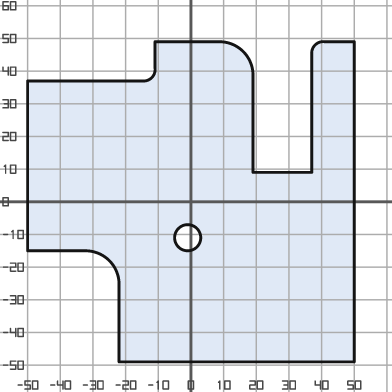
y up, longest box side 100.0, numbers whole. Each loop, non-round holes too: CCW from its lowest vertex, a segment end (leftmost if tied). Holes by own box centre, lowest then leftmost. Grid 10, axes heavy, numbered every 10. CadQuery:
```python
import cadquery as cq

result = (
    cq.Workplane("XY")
    .moveTo(-22.0, -49.0)
    .lineTo(50.0, -49.0)
    .lineTo(50.0, 49.0)
    .lineTo(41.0, 49.0)
    .threePointArc((38.0, 48.0), (37.0, 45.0))
    .lineTo(37.0, 9.0)
    .lineTo(19.0, 9.0)
    .lineTo(19.0, 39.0)
    .threePointArc((16.0, 46.0), (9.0, 49.0))
    .lineTo(-11.0, 49.0)
    .lineTo(-11.0, 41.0)
    .threePointArc((-12.0, 38.0), (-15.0, 37.0))
    .lineTo(-50.0, 37.0)
    .lineTo(-50.0, -15.0)
    .lineTo(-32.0, -15.0)
    .threePointArc((-25.0, -18.0), (-22.0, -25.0))
    .close()
    .moveTo(-1.0, -11.0)
    .circle(4.0)
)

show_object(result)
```